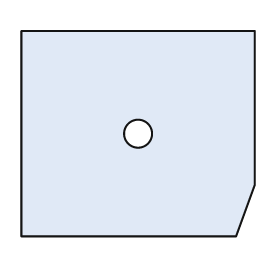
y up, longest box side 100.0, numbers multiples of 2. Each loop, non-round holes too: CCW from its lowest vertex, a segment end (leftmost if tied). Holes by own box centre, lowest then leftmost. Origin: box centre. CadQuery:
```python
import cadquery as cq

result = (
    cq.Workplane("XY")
    .moveTo(-50.0, -44.0)
    .lineTo(42.0, -44.0)
    .lineTo(50.0, -22.0)
    .lineTo(50.0, 44.0)
    .lineTo(-50.0, 44.0)
    .close()
    .moveTo(0.0, 0.0)
    .circle(6.0)
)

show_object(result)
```